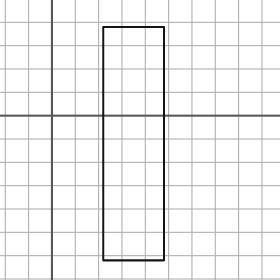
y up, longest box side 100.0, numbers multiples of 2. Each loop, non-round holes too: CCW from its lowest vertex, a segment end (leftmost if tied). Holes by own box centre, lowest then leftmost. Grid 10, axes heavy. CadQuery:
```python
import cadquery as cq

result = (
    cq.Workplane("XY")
    .moveTo(22.0, -62.0)
    .lineTo(48.0, -62.0)
    .lineTo(48.0, 38.0)
    .lineTo(22.0, 38.0)
    .close()
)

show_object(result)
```